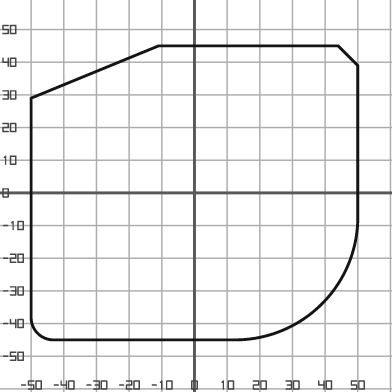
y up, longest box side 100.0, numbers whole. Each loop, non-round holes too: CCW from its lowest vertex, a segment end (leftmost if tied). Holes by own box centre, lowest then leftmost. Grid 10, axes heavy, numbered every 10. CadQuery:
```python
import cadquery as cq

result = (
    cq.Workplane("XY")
    .moveTo(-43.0, -45.0)
    .lineTo(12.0, -45.0)
    .threePointArc((39.0, -34.0), (50.0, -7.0))
    .lineTo(50.0, 39.0)
    .lineTo(44.0, 45.0)
    .lineTo(-11.0, 45.0)
    .lineTo(-50.0, 29.0)
    .lineTo(-50.0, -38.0)
    .threePointArc((-48.0, -43.0), (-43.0, -45.0))
    .close()
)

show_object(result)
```